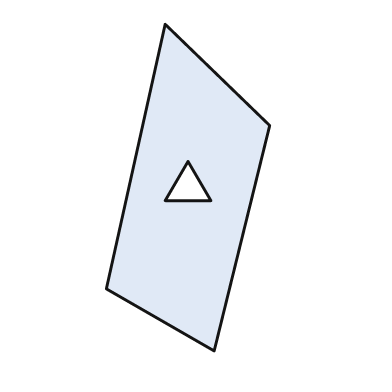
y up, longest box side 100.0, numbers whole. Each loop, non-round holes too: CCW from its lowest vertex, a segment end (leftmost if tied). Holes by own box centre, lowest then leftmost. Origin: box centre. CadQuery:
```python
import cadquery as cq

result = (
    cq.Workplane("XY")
    .moveTo(8.0, -50.0)
    .lineTo(25.0, 19.0)
    .lineTo(-7.0, 50.0)
    .lineTo(-25.0, -31.0)
    .close()
    .moveTo(-7.0, -4.0)
    .lineTo(7.0, -4.0)
    .lineTo(0.0, 8.0)
    .close()
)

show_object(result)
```